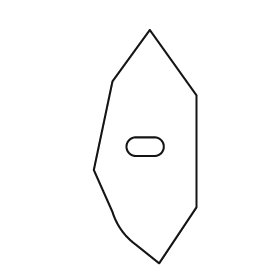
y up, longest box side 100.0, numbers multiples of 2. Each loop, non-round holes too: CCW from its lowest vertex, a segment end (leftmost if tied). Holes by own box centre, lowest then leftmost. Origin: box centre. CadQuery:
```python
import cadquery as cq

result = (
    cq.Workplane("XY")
    .moveTo(6.0, -50.0)
    .lineTo(22.0, -26.0)
    .lineTo(22.0, 22.0)
    .lineTo(2.0, 50.0)
    .lineTo(-14.0, 28.0)
    .lineTo(-22.0, -10.0)
    .lineTo(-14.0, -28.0)
    .threePointArc((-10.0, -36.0), (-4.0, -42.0))
    .close()
    .moveTo(-4.0, -4.0)
    .lineTo(4.0, -4.0)
    .threePointArc((8.0, 0.0), (4.0, 4.0))
    .lineTo(-4.0, 4.0)
    .threePointArc((-8.0, 0.0), (-4.0, -4.0))
    .close()
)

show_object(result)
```